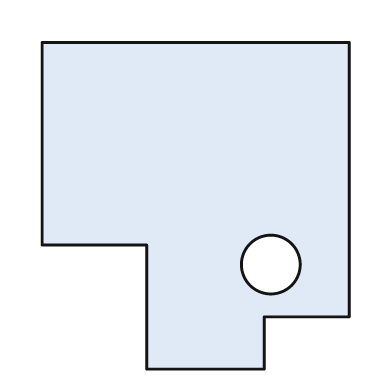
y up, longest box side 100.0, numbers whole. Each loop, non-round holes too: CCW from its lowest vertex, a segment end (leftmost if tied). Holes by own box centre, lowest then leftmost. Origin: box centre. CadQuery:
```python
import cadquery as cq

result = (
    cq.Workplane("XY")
    .moveTo(-15.0, -50.0)
    .lineTo(21.0, -50.0)
    .lineTo(21.0, -34.0)
    .lineTo(47.0, -34.0)
    .lineTo(47.0, 50.0)
    .lineTo(-47.0, 50.0)
    .lineTo(-47.0, -12.0)
    .lineTo(-15.0, -12.0)
    .close()
    .moveTo(23.0, -18.0)
    .circle(9.0)
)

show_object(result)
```